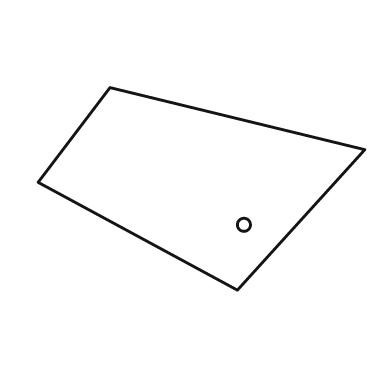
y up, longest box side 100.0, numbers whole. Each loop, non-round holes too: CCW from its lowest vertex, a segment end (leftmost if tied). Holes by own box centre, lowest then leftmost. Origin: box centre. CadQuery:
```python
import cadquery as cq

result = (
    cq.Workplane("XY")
    .moveTo(11.0, -31.0)
    .lineTo(50.0, 12.0)
    .lineTo(-28.0, 31.0)
    .lineTo(-50.0, 2.0)
    .close()
    .moveTo(13.0, -11.0)
    .circle(2.0)
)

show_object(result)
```